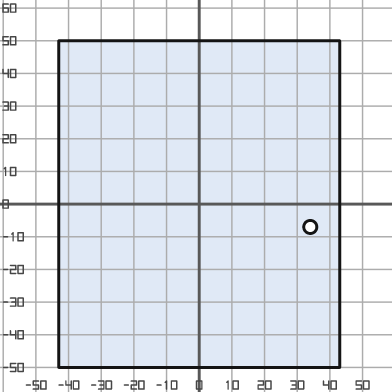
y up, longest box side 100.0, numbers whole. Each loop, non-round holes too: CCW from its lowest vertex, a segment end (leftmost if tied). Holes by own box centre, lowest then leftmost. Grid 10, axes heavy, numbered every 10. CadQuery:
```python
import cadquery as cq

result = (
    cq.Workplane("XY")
    .moveTo(-43.0, -50.0)
    .lineTo(43.0, -50.0)
    .lineTo(43.0, 50.0)
    .lineTo(-43.0, 50.0)
    .close()
    .moveTo(34.0, -7.0)
    .circle(2.0)
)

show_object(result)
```